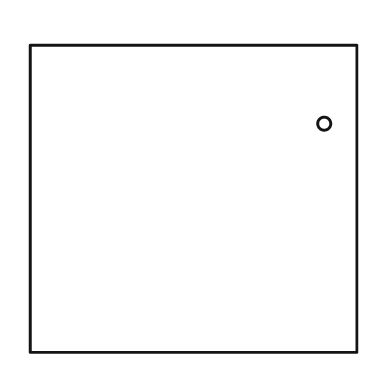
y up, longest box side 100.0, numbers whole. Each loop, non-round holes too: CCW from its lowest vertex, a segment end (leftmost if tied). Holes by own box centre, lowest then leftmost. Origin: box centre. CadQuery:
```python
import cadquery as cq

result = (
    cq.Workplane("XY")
    .moveTo(-50.0, -47.0)
    .lineTo(50.0, -47.0)
    .lineTo(50.0, 47.0)
    .lineTo(-50.0, 47.0)
    .close()
    .moveTo(40.0, 23.0)
    .circle(2.0)
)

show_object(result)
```